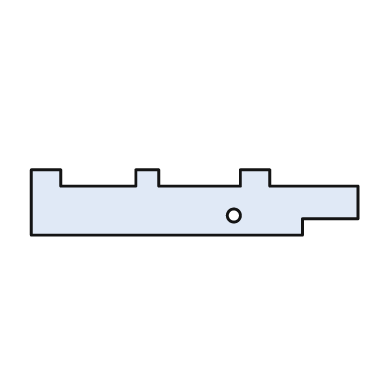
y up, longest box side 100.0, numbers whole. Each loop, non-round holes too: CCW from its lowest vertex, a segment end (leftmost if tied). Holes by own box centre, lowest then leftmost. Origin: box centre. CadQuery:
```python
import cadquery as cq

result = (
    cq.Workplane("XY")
    .moveTo(-50.0, -10.0)
    .lineTo(33.0, -10.0)
    .lineTo(33.0, -5.0)
    .lineTo(50.0, -5.0)
    .lineTo(50.0, 5.0)
    .lineTo(23.0, 5.0)
    .lineTo(23.0, 10.0)
    .lineTo(14.0, 10.0)
    .lineTo(14.0, 5.0)
    .lineTo(-11.0, 5.0)
    .lineTo(-11.0, 10.0)
    .lineTo(-18.0, 10.0)
    .lineTo(-18.0, 5.0)
    .lineTo(-41.0, 5.0)
    .lineTo(-41.0, 10.0)
    .lineTo(-50.0, 10.0)
    .close()
    .moveTo(12.0, -4.0)
    .circle(2.0)
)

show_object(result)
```